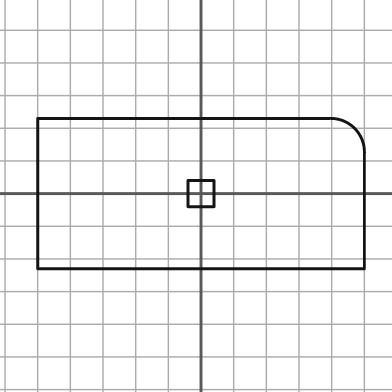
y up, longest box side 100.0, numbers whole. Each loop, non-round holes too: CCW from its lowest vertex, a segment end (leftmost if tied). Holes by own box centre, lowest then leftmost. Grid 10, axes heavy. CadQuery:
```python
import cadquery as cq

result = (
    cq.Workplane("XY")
    .moveTo(-50.0, -23.0)
    .lineTo(50.0, -23.0)
    .lineTo(50.0, 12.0)
    .threePointArc((47.0, 20.0), (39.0, 23.0))
    .lineTo(-50.0, 23.0)
    .close()
    .moveTo(-4.0, -4.0)
    .lineTo(4.0, -4.0)
    .lineTo(4.0, 4.0)
    .lineTo(-4.0, 4.0)
    .close()
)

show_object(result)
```